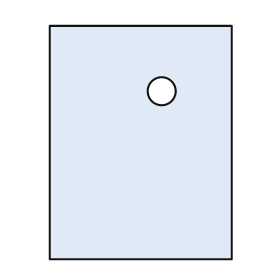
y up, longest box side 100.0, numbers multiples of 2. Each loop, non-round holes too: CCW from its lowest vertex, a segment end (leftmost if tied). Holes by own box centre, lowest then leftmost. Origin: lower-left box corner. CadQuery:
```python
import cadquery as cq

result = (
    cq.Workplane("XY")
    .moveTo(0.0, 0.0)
    .lineTo(78.0, 0.0)
    .lineTo(78.0, 100.0)
    .lineTo(0.0, 100.0)
    .close()
    .moveTo(48.0, 72.0)
    .circle(6.0)
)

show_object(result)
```